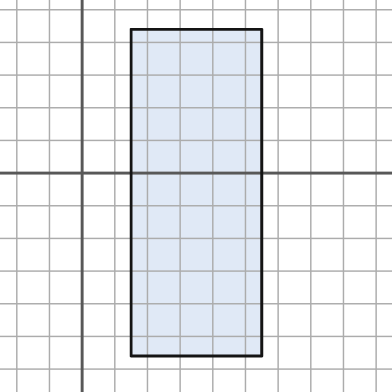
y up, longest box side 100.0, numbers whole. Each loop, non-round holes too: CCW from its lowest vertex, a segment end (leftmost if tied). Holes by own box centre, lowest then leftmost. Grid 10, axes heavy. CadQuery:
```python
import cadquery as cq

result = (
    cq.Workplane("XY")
    .moveTo(15.0, -56.0)
    .lineTo(55.0, -56.0)
    .lineTo(55.0, 44.0)
    .lineTo(15.0, 44.0)
    .close()
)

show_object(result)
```